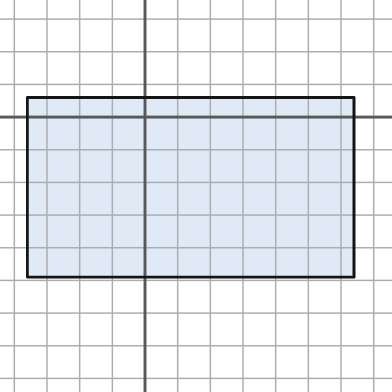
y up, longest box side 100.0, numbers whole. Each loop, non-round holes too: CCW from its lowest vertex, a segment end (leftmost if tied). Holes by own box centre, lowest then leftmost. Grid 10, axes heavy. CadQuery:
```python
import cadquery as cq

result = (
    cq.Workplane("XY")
    .moveTo(-36.0, -49.0)
    .lineTo(64.0, -49.0)
    .lineTo(64.0, 6.0)
    .lineTo(-36.0, 6.0)
    .close()
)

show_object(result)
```